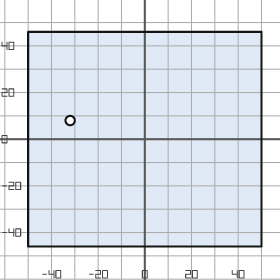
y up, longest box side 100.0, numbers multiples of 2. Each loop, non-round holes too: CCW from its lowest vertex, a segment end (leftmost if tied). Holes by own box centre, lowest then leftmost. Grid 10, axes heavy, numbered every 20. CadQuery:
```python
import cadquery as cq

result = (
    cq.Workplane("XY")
    .moveTo(-50.0, -46.0)
    .lineTo(50.0, -46.0)
    .lineTo(50.0, 46.0)
    .lineTo(-50.0, 46.0)
    .close()
    .moveTo(-32.0, 8.0)
    .circle(2.0)
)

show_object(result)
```